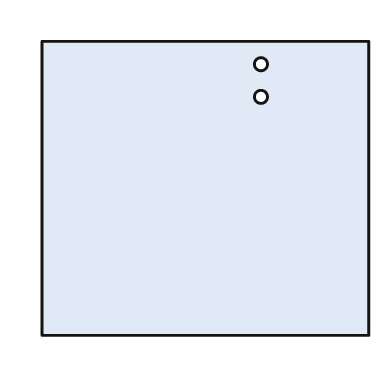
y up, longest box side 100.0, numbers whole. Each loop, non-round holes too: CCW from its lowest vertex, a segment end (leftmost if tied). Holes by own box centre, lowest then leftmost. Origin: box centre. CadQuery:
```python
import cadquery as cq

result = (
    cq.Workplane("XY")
    .moveTo(-50.0, -45.0)
    .lineTo(50.0, -45.0)
    .lineTo(50.0, 45.0)
    .lineTo(-50.0, 45.0)
    .close()
    .moveTo(17.0, 28.0)
    .circle(2.0)
    .moveTo(17.0, 38.0)
    .circle(2.0)
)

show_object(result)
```